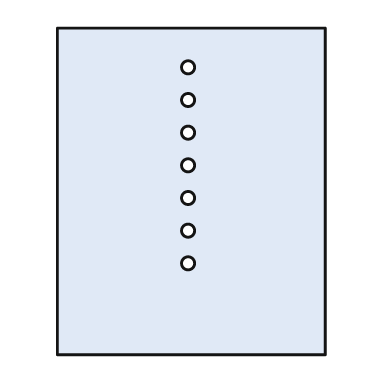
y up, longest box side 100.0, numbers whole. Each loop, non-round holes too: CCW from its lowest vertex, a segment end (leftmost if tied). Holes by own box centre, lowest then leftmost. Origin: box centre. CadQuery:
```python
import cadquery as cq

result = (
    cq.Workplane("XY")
    .moveTo(-41.0, -50.0)
    .lineTo(41.0, -50.0)
    .lineTo(41.0, 50.0)
    .lineTo(-41.0, 50.0)
    .close()
    .moveTo(-1.0, -22.0)
    .circle(2.0)
    .moveTo(-1.0, -12.0)
    .circle(2.0)
    .moveTo(-1.0, -2.0)
    .circle(2.0)
    .moveTo(-1.0, 8.0)
    .circle(2.0)
    .moveTo(-1.0, 18.0)
    .circle(2.0)
    .moveTo(-1.0, 28.0)
    .circle(2.0)
    .moveTo(-1.0, 38.0)
    .circle(2.0)
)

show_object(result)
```